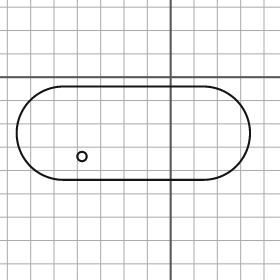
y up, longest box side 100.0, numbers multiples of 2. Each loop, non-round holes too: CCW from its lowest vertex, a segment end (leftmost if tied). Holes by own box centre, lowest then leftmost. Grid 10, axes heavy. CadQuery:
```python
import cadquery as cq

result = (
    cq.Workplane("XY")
    .moveTo(-46.0, -44.0)
    .lineTo(14.0, -44.0)
    .threePointArc((34.0, -24.0), (14.0, -4.0))
    .lineTo(-46.0, -4.0)
    .threePointArc((-66.0, -24.0), (-46.0, -44.0))
    .close()
    .moveTo(-38.0, -34.0)
    .circle(2.0)
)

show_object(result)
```